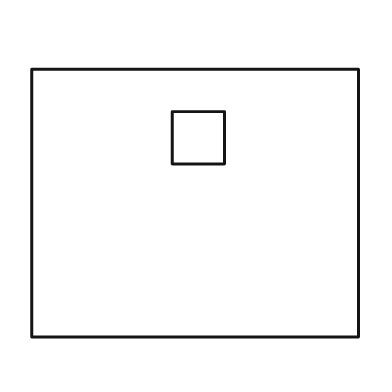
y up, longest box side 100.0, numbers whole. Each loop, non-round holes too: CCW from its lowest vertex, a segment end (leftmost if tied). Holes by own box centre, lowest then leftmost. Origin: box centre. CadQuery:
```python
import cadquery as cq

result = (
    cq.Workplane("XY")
    .moveTo(-50.0, -41.0)
    .lineTo(50.0, -41.0)
    .lineTo(50.0, 41.0)
    .lineTo(-50.0, 41.0)
    .close()
    .moveTo(-7.0, 12.0)
    .lineTo(9.0, 12.0)
    .lineTo(9.0, 28.0)
    .lineTo(-7.0, 28.0)
    .close()
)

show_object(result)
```